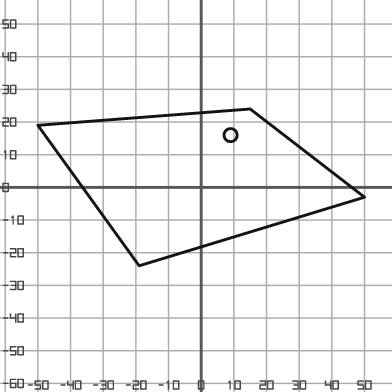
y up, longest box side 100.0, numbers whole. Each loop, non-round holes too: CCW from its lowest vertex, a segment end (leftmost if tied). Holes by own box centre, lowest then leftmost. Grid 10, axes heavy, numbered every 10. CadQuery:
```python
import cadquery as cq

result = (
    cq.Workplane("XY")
    .moveTo(-19.0, -24.0)
    .lineTo(50.0, -3.0)
    .lineTo(15.0, 24.0)
    .lineTo(-50.0, 19.0)
    .close()
    .moveTo(9.0, 16.0)
    .circle(2.0)
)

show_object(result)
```